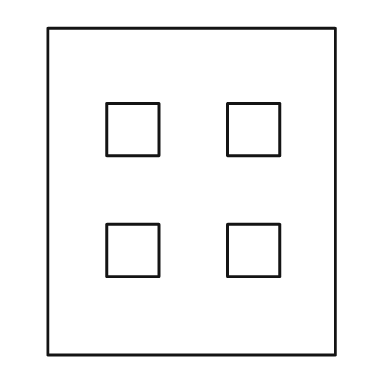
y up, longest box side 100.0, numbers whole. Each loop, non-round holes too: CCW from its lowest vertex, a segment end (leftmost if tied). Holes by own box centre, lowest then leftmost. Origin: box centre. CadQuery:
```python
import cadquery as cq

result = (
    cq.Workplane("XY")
    .moveTo(-44.0, -50.0)
    .lineTo(44.0, -50.0)
    .lineTo(44.0, 50.0)
    .lineTo(-44.0, 50.0)
    .close()
    .moveTo(-26.0, -26.0)
    .lineTo(-10.0, -26.0)
    .lineTo(-10.0, -10.0)
    .lineTo(-26.0, -10.0)
    .close()
    .moveTo(11.0, -26.0)
    .lineTo(27.0, -26.0)
    .lineTo(27.0, -10.0)
    .lineTo(11.0, -10.0)
    .close()
    .moveTo(-26.0, 11.0)
    .lineTo(-10.0, 11.0)
    .lineTo(-10.0, 27.0)
    .lineTo(-26.0, 27.0)
    .close()
    .moveTo(11.0, 11.0)
    .lineTo(27.0, 11.0)
    .lineTo(27.0, 27.0)
    .lineTo(11.0, 27.0)
    .close()
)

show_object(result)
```